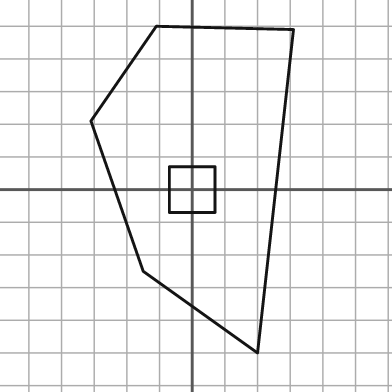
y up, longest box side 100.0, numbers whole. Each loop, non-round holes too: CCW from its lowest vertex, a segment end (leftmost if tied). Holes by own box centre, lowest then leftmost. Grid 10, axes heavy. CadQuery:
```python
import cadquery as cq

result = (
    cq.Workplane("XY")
    .moveTo(20.0, -50.0)
    .lineTo(31.0, 49.0)
    .lineTo(-11.0, 50.0)
    .lineTo(-31.0, 21.0)
    .lineTo(-15.0, -25.0)
    .close()
    .moveTo(-7.0, -7.0)
    .lineTo(7.0, -7.0)
    .lineTo(7.0, 7.0)
    .lineTo(-7.0, 7.0)
    .close()
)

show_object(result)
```